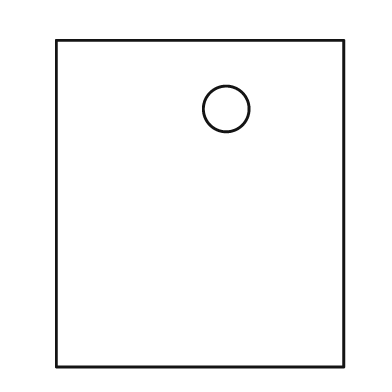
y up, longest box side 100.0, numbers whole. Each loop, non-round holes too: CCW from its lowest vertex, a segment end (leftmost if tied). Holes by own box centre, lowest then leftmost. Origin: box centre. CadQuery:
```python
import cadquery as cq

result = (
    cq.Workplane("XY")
    .moveTo(-44.0, -50.0)
    .lineTo(44.0, -50.0)
    .lineTo(44.0, 50.0)
    .lineTo(-44.0, 50.0)
    .close()
    .moveTo(8.0, 29.0)
    .circle(7.0)
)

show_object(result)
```